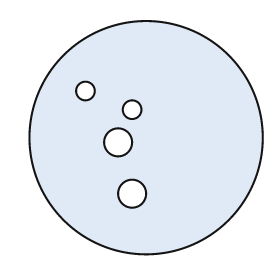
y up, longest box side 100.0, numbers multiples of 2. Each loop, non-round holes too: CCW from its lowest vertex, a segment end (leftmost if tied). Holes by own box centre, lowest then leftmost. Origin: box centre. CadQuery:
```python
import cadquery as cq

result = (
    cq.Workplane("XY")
    .moveTo(0.0, 0.0)
    .circle(50.0)
    .moveTo(-6.0, -24.0)
    .circle(6.0)
    .moveTo(-12.0, -2.0)
    .circle(6.0)
    .moveTo(-6.0, 12.0)
    .circle(4.0)
    .moveTo(-26.0, 20.0)
    .circle(4.0)
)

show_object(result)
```